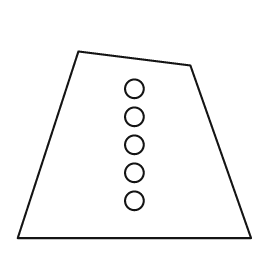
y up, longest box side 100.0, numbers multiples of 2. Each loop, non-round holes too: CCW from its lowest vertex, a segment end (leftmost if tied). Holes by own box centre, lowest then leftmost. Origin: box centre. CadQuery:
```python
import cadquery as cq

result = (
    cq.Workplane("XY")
    .moveTo(-50.0, -40.0)
    .lineTo(50.0, -40.0)
    .lineTo(24.0, 34.0)
    .lineTo(-24.0, 40.0)
    .close()
    .moveTo(0.0, -24.0)
    .circle(4.0)
    .moveTo(0.0, -12.0)
    .circle(4.0)
    .moveTo(0.0, 0.0)
    .circle(4.0)
    .moveTo(0.0, 12.0)
    .circle(4.0)
    .moveTo(0.0, 24.0)
    .circle(4.0)
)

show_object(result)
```